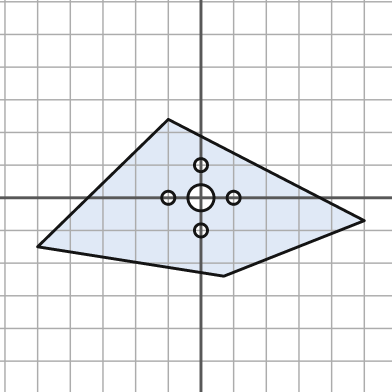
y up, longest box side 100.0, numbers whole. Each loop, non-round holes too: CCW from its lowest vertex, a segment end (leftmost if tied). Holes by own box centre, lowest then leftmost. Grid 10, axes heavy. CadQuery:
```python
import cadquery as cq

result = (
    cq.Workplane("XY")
    .moveTo(7.0, -24.0)
    .lineTo(50.0, -7.0)
    .lineTo(-10.0, 24.0)
    .lineTo(-50.0, -15.0)
    .close()
    .moveTo(0.0, -10.0)
    .circle(2.0)
    .moveTo(-10.0, 0.0)
    .circle(2.0)
    .moveTo(0.0, 0.0)
    .circle(4.0)
    .moveTo(10.0, 0.0)
    .circle(2.0)
    .moveTo(0.0, 10.0)
    .circle(2.0)
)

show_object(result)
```